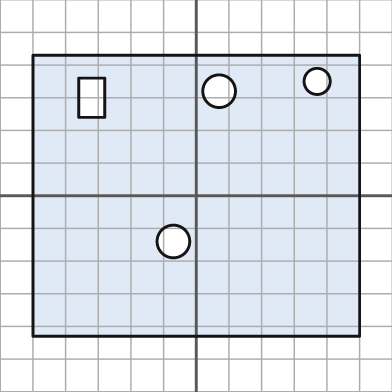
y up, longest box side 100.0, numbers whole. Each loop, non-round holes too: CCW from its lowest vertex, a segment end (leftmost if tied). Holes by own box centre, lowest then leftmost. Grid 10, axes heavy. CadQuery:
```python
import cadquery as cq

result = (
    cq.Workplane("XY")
    .moveTo(-50.0, -43.0)
    .lineTo(50.0, -43.0)
    .lineTo(50.0, 43.0)
    .lineTo(-50.0, 43.0)
    .close()
    .moveTo(-7.0, -14.0)
    .circle(5.0)
    .moveTo(-36.0, 24.0)
    .lineTo(-28.0, 24.0)
    .lineTo(-28.0, 36.0)
    .lineTo(-36.0, 36.0)
    .close()
    .moveTo(7.0, 32.0)
    .circle(5.0)
    .moveTo(37.0, 35.0)
    .circle(4.0)
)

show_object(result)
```